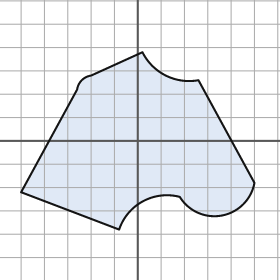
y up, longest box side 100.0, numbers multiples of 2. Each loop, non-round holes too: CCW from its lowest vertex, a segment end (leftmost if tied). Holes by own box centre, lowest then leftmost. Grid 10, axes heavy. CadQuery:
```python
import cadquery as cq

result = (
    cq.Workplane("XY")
    .moveTo(-8.0, -38.0)
    .threePointArc((2.0, -26.0), (18.0, -24.0))
    .threePointArc((36.0, -32.0), (50.0, -18.0))
    .lineTo(26.0, 26.0)
    .threePointArc((12.0, 28.0), (2.0, 38.0))
    .lineTo(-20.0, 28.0)
    .threePointArc((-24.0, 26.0), (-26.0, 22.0))
    .lineTo(-50.0, -22.0)
    .close()
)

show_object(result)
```